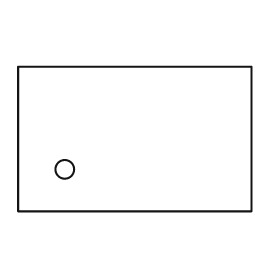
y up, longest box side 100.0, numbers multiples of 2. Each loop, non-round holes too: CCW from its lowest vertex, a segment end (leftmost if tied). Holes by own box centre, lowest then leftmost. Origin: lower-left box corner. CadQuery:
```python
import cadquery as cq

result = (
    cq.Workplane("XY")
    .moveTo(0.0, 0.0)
    .lineTo(100.0, 0.0)
    .lineTo(100.0, 62.0)
    .lineTo(0.0, 62.0)
    .close()
    .moveTo(20.0, 18.0)
    .circle(4.0)
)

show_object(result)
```